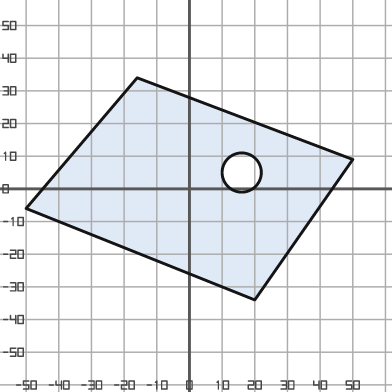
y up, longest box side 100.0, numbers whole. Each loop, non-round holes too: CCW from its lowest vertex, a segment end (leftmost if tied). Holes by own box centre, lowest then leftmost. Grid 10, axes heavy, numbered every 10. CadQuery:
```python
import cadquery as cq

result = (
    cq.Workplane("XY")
    .moveTo(20.0, -34.0)
    .lineTo(50.0, 9.0)
    .lineTo(-16.0, 34.0)
    .lineTo(-50.0, -6.0)
    .close()
    .moveTo(16.0, 5.0)
    .circle(6.0)
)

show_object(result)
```